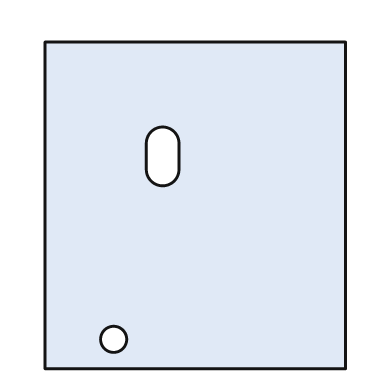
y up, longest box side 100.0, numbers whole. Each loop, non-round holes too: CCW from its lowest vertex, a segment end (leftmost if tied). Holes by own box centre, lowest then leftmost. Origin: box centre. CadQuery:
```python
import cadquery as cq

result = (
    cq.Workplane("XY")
    .moveTo(-46.0, -50.0)
    .lineTo(46.0, -50.0)
    .lineTo(46.0, 50.0)
    .lineTo(-46.0, 50.0)
    .close()
    .moveTo(-25.0, -41.0)
    .circle(4.0)
    .moveTo(-15.0, 11.0)
    .threePointArc((-10.0, 6.0), (-5.0, 11.0))
    .lineTo(-5.0, 19.0)
    .threePointArc((-10.0, 24.0), (-15.0, 19.0))
    .close()
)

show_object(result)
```